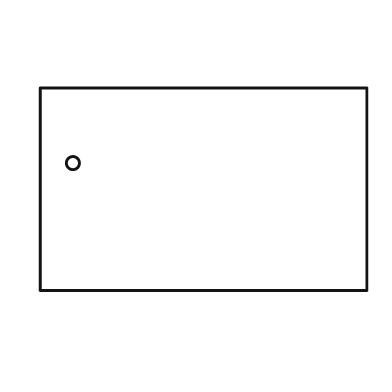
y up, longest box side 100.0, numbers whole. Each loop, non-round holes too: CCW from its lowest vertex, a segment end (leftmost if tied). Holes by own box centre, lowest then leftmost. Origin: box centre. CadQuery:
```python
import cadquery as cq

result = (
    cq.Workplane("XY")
    .moveTo(-50.0, -31.0)
    .lineTo(50.0, -31.0)
    .lineTo(50.0, 31.0)
    .lineTo(-50.0, 31.0)
    .close()
    .moveTo(-40.0, 8.0)
    .circle(2.0)
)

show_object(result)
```